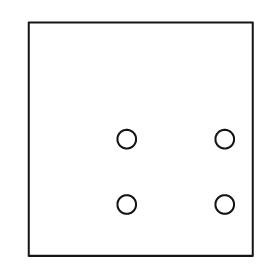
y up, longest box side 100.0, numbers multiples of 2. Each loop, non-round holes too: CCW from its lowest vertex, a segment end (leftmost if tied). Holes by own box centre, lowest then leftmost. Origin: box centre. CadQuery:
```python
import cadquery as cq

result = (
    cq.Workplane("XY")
    .moveTo(-48.0, -50.0)
    .lineTo(48.0, -50.0)
    .lineTo(48.0, 50.0)
    .lineTo(-48.0, 50.0)
    .close()
    .moveTo(-6.0, -28.0)
    .circle(4.0)
    .moveTo(36.0, -28.0)
    .circle(4.0)
    .moveTo(-6.0, 0.0)
    .circle(4.0)
    .moveTo(36.0, 0.0)
    .circle(4.0)
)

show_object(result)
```